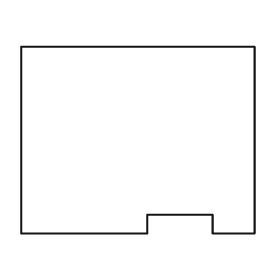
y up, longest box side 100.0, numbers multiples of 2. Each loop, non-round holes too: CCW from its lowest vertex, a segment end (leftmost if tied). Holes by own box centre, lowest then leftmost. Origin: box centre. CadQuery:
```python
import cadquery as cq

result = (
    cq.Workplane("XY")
    .moveTo(-50.0, -40.0)
    .lineTo(4.0, -40.0)
    .lineTo(4.0, -32.0)
    .lineTo(32.0, -32.0)
    .lineTo(32.0, -40.0)
    .lineTo(50.0, -40.0)
    .lineTo(50.0, 40.0)
    .lineTo(-50.0, 40.0)
    .close()
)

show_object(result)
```